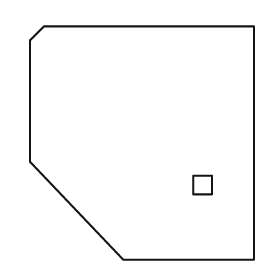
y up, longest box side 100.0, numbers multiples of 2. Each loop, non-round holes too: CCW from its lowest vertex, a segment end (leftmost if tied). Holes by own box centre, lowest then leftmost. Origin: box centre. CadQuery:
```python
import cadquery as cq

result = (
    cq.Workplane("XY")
    .moveTo(-8.0, -50.0)
    .lineTo(48.0, -50.0)
    .lineTo(48.0, 50.0)
    .lineTo(-42.0, 50.0)
    .lineTo(-48.0, 44.0)
    .lineTo(-48.0, -8.0)
    .close()
    .moveTo(22.0, -22.0)
    .lineTo(30.0, -22.0)
    .lineTo(30.0, -14.0)
    .lineTo(22.0, -14.0)
    .close()
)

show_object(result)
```